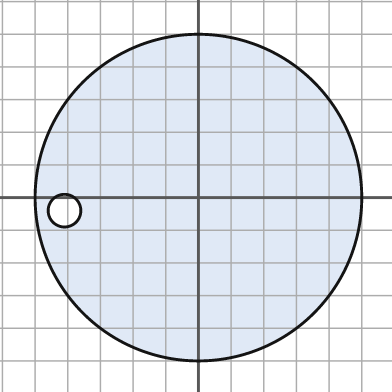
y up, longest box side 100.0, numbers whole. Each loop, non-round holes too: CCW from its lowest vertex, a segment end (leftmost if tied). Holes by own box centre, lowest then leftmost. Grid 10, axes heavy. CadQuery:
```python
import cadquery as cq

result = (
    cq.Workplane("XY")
    .moveTo(0.0, 0.0)
    .circle(50.0)
    .moveTo(-41.0, -4.0)
    .circle(5.0)
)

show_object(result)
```